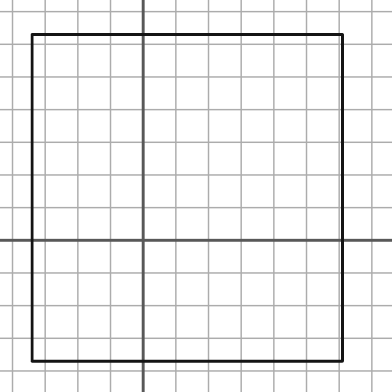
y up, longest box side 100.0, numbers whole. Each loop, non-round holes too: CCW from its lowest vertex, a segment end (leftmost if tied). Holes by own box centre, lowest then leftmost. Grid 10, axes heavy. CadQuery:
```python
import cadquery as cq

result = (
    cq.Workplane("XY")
    .moveTo(-34.0, -37.0)
    .lineTo(61.0, -37.0)
    .lineTo(61.0, 63.0)
    .lineTo(-34.0, 63.0)
    .close()
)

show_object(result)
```